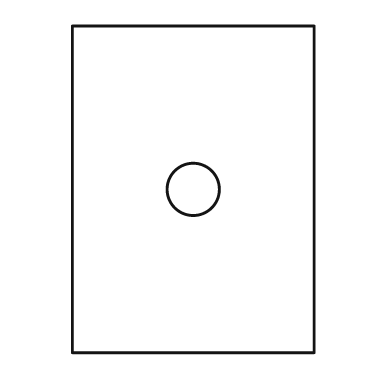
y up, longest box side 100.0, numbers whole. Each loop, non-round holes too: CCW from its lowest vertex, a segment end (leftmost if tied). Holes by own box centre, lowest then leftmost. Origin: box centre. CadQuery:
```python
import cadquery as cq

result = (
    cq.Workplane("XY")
    .moveTo(-37.0, -50.0)
    .lineTo(37.0, -50.0)
    .lineTo(37.0, 50.0)
    .lineTo(-37.0, 50.0)
    .close()
    .moveTo(0.0, 0.0)
    .circle(8.0)
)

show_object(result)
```